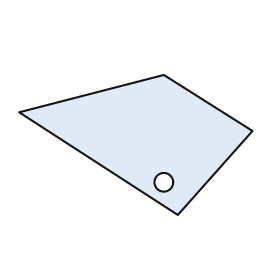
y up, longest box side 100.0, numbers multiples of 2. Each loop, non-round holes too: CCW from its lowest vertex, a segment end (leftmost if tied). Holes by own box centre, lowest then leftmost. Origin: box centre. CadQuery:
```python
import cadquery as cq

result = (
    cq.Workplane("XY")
    .moveTo(18.0, -30.0)
    .lineTo(50.0, 6.0)
    .lineTo(12.0, 30.0)
    .lineTo(-50.0, 14.0)
    .close()
    .moveTo(12.0, -16.0)
    .circle(4.0)
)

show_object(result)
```